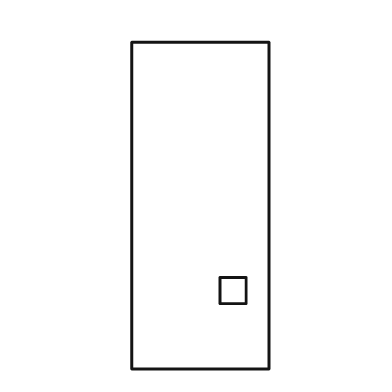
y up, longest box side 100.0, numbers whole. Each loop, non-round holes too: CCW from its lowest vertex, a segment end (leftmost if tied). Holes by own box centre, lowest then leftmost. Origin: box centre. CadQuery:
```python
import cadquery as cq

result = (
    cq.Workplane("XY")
    .moveTo(-21.0, -50.0)
    .lineTo(21.0, -50.0)
    .lineTo(21.0, 50.0)
    .lineTo(-21.0, 50.0)
    .close()
    .moveTo(6.0, -30.0)
    .lineTo(14.0, -30.0)
    .lineTo(14.0, -22.0)
    .lineTo(6.0, -22.0)
    .close()
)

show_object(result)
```